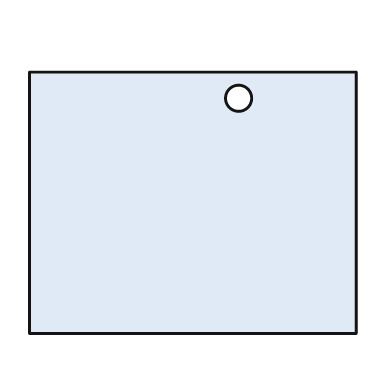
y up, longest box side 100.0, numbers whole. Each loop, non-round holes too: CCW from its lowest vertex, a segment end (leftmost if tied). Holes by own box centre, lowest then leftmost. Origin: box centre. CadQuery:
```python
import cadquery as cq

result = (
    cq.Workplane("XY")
    .moveTo(-50.0, -40.0)
    .lineTo(50.0, -40.0)
    .lineTo(50.0, 40.0)
    .lineTo(-50.0, 40.0)
    .close()
    .moveTo(14.0, 32.0)
    .circle(4.0)
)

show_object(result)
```